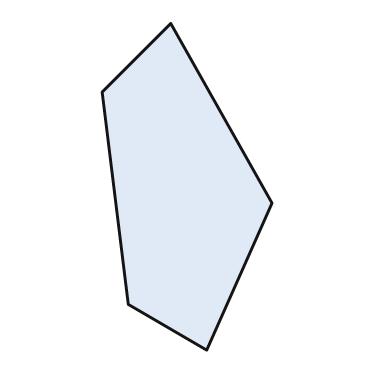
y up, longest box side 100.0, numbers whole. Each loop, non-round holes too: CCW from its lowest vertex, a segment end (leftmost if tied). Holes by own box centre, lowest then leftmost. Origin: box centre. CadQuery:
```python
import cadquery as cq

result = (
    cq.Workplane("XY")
    .moveTo(6.0, -50.0)
    .lineTo(26.0, -5.0)
    .lineTo(-5.0, 50.0)
    .lineTo(-26.0, 29.0)
    .lineTo(-18.0, -36.0)
    .close()
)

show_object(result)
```